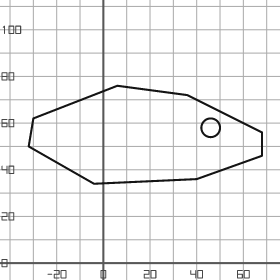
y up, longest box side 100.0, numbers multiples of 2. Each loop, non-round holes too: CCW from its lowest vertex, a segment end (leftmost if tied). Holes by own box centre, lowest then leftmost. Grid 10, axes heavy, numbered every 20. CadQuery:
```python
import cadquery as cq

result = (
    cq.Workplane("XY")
    .moveTo(-4.0, 34.0)
    .lineTo(40.0, 36.0)
    .lineTo(68.0, 46.0)
    .lineTo(68.0, 56.0)
    .lineTo(36.0, 72.0)
    .lineTo(6.0, 76.0)
    .lineTo(-30.0, 62.0)
    .lineTo(-32.0, 50.0)
    .close()
    .moveTo(46.0, 58.0)
    .circle(4.0)
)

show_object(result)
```